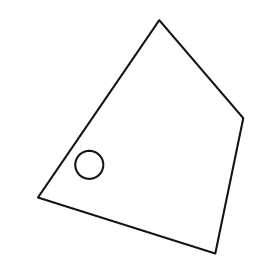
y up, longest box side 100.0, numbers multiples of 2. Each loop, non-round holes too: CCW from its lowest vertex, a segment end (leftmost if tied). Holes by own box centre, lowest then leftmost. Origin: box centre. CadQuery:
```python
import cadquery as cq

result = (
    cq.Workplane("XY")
    .moveTo(32.0, -50.0)
    .lineTo(44.0, 8.0)
    .lineTo(8.0, 50.0)
    .lineTo(-44.0, -26.0)
    .close()
    .moveTo(-22.0, -12.0)
    .circle(6.0)
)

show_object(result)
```